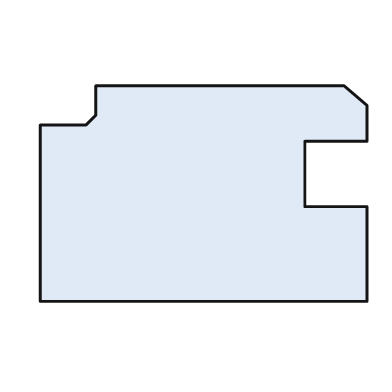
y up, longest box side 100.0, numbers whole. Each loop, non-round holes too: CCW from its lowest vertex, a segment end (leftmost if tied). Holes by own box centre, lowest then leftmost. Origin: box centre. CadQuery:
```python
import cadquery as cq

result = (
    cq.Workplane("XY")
    .moveTo(-50.0, -33.0)
    .lineTo(50.0, -33.0)
    .lineTo(50.0, -4.0)
    .lineTo(31.0, -4.0)
    .lineTo(31.0, 16.0)
    .lineTo(50.0, 16.0)
    .lineTo(50.0, 27.0)
    .lineTo(43.0, 33.0)
    .lineTo(-33.0, 33.0)
    .lineTo(-33.0, 24.0)
    .lineTo(-36.0, 21.0)
    .lineTo(-50.0, 21.0)
    .close()
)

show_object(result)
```